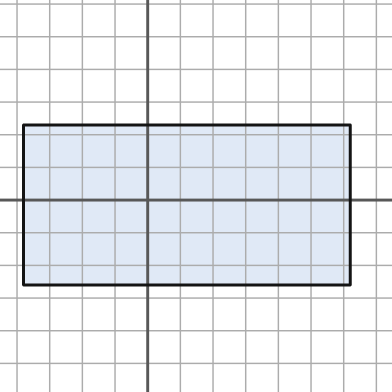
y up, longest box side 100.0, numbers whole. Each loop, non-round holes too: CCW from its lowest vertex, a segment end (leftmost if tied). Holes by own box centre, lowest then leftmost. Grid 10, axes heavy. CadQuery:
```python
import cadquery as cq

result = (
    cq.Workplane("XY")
    .moveTo(-38.0, -26.0)
    .lineTo(62.0, -26.0)
    .lineTo(62.0, 23.0)
    .lineTo(-38.0, 23.0)
    .close()
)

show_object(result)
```